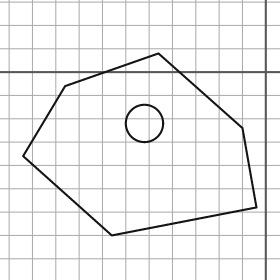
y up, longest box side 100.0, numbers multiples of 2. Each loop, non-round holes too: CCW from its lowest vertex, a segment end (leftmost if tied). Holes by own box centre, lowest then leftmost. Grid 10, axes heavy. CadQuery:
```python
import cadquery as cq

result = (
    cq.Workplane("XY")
    .moveTo(-66.0, -70.0)
    .lineTo(-4.0, -58.0)
    .lineTo(-10.0, -24.0)
    .lineTo(-46.0, 8.0)
    .lineTo(-86.0, -6.0)
    .lineTo(-104.0, -36.0)
    .close()
    .moveTo(-52.0, -22.0)
    .circle(8.0)
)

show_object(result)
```